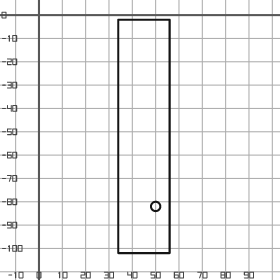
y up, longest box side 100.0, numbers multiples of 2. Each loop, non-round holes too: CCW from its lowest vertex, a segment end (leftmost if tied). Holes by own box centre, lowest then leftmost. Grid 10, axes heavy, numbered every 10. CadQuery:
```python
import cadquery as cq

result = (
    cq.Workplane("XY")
    .moveTo(34.0, -102.0)
    .lineTo(56.0, -102.0)
    .lineTo(56.0, -2.0)
    .lineTo(34.0, -2.0)
    .close()
    .moveTo(50.0, -82.0)
    .circle(2.0)
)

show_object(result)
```